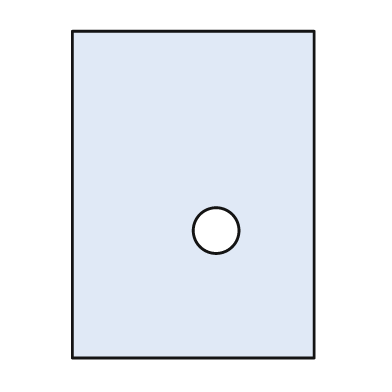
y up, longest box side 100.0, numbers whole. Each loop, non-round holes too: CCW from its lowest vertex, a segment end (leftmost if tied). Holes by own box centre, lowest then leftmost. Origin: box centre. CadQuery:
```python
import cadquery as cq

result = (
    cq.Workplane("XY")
    .moveTo(-37.0, -50.0)
    .lineTo(37.0, -50.0)
    .lineTo(37.0, 50.0)
    .lineTo(-37.0, 50.0)
    .close()
    .moveTo(7.0, -11.0)
    .circle(7.0)
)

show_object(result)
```